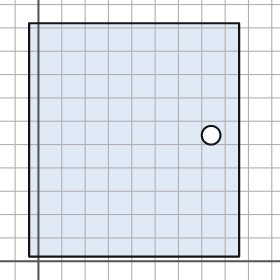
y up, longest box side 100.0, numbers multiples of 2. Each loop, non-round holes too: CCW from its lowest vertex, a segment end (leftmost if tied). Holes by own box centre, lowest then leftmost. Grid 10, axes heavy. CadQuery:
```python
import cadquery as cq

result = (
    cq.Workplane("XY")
    .moveTo(-4.0, 2.0)
    .lineTo(86.0, 2.0)
    .lineTo(86.0, 102.0)
    .lineTo(-4.0, 102.0)
    .close()
    .moveTo(74.0, 54.0)
    .circle(4.0)
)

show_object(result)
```